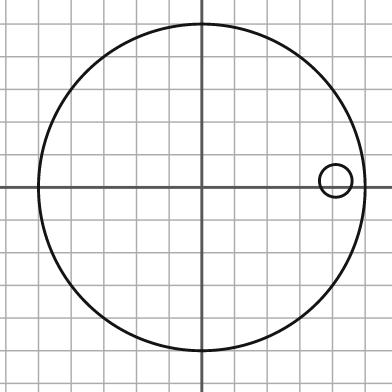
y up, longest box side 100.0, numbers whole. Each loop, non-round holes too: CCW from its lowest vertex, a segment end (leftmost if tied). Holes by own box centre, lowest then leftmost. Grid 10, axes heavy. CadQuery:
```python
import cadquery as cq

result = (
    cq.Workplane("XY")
    .moveTo(0.0, 0.0)
    .circle(50.0)
    .moveTo(41.0, 2.0)
    .circle(5.0)
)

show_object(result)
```